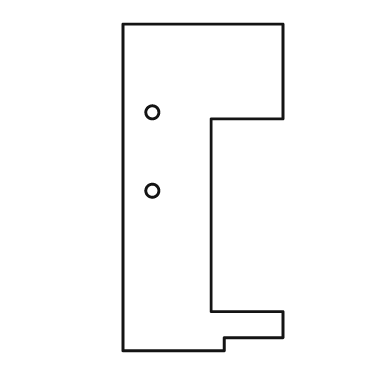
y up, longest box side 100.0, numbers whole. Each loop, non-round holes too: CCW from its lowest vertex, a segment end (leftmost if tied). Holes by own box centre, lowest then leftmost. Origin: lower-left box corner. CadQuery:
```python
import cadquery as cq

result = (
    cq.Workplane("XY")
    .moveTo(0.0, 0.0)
    .lineTo(31.0, 0.0)
    .lineTo(31.0, 4.0)
    .lineTo(49.0, 4.0)
    .lineTo(49.0, 12.0)
    .lineTo(27.0, 12.0)
    .lineTo(27.0, 71.0)
    .lineTo(49.0, 71.0)
    .lineTo(49.0, 100.0)
    .lineTo(0.0, 100.0)
    .close()
    .moveTo(9.0, 49.0)
    .circle(2.0)
    .moveTo(9.0, 73.0)
    .circle(2.0)
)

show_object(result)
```